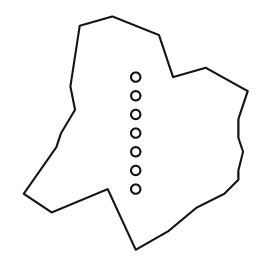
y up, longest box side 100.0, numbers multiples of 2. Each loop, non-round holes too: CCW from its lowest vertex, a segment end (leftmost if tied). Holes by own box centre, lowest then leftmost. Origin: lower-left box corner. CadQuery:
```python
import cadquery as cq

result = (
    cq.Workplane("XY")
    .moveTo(48.0, 0.0)
    .lineTo(62.0, 8.0)
    .lineTo(74.0, 18.0)
    .lineTo(86.0, 24.0)
    .lineTo(92.0, 30.0)
    .lineTo(92.0, 34.0)
    .lineTo(94.0, 42.0)
    .lineTo(92.0, 48.0)
    .lineTo(92.0, 56.0)
    .lineTo(96.0, 68.0)
    .lineTo(78.0, 78.0)
    .lineTo(64.0, 74.0)
    .lineTo(58.0, 92.0)
    .lineTo(38.0, 100.0)
    .lineTo(24.0, 96.0)
    .lineTo(20.0, 70.0)
    .lineTo(22.0, 60.0)
    .lineTo(16.0, 50.0)
    .lineTo(14.0, 44.0)
    .lineTo(0.0, 24.0)
    .lineTo(12.0, 16.0)
    .lineTo(36.0, 26.0)
    .close()
    .moveTo(48.0, 26.0)
    .circle(2.0)
    .moveTo(48.0, 34.0)
    .circle(2.0)
    .moveTo(48.0, 42.0)
    .circle(2.0)
    .moveTo(48.0, 50.0)
    .circle(2.0)
    .moveTo(48.0, 58.0)
    .circle(2.0)
    .moveTo(48.0, 66.0)
    .circle(2.0)
    .moveTo(48.0, 74.0)
    .circle(2.0)
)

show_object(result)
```